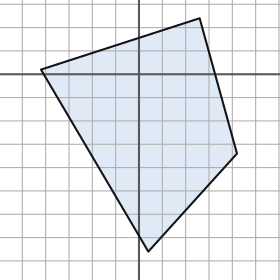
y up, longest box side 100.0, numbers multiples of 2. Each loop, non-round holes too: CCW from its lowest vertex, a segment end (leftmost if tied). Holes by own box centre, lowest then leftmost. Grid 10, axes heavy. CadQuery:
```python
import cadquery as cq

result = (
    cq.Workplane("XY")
    .moveTo(4.0, -76.0)
    .lineTo(42.0, -34.0)
    .lineTo(26.0, 24.0)
    .lineTo(-42.0, 2.0)
    .close()
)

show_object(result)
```